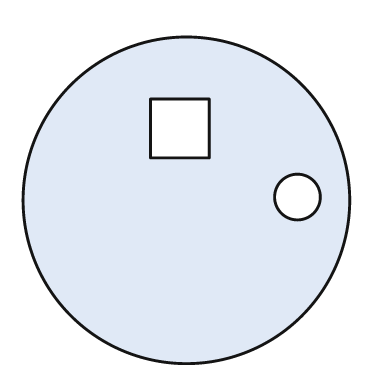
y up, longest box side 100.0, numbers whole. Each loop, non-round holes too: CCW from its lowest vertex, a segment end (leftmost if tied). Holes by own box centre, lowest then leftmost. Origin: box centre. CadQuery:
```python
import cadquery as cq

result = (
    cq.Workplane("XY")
    .moveTo(0.0, 0.0)
    .circle(50.0)
    .moveTo(34.0, 1.0)
    .circle(7.0)
    .moveTo(-11.0, 13.0)
    .lineTo(7.0, 13.0)
    .lineTo(7.0, 31.0)
    .lineTo(-11.0, 31.0)
    .close()
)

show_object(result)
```